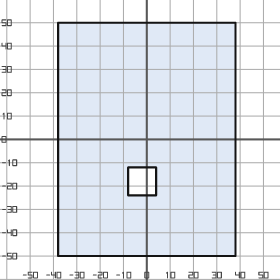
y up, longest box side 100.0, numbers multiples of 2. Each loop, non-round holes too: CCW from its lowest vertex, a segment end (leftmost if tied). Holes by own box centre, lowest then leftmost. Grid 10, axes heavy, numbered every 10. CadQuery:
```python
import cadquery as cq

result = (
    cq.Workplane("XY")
    .moveTo(-38.0, -50.0)
    .lineTo(38.0, -50.0)
    .lineTo(38.0, 50.0)
    .lineTo(-38.0, 50.0)
    .close()
    .moveTo(-8.0, -24.0)
    .lineTo(4.0, -24.0)
    .lineTo(4.0, -12.0)
    .lineTo(-8.0, -12.0)
    .close()
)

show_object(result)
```